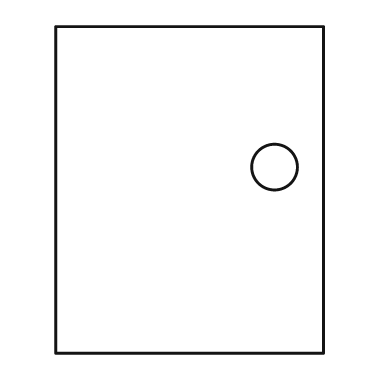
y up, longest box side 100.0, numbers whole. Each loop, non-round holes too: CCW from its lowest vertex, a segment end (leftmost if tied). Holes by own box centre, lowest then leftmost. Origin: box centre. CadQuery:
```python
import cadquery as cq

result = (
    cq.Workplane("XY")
    .moveTo(-41.0, -50.0)
    .lineTo(41.0, -50.0)
    .lineTo(41.0, 50.0)
    .lineTo(-41.0, 50.0)
    .close()
    .moveTo(26.0, 7.0)
    .circle(7.0)
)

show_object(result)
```